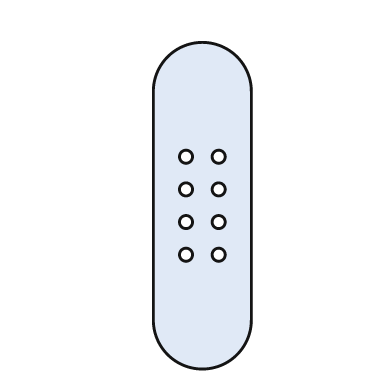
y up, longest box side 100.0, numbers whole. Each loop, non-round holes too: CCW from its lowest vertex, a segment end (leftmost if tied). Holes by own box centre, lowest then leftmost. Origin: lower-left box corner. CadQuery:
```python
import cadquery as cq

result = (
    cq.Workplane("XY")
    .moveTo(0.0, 15.0)
    .threePointArc((15.0, 0.0), (30.0, 15.0))
    .lineTo(30.0, 85.0)
    .threePointArc((15.0, 100.0), (0.0, 85.0))
    .close()
    .moveTo(10.0, 35.0)
    .circle(2.0)
    .moveTo(20.0, 35.0)
    .circle(2.0)
    .moveTo(10.0, 45.0)
    .circle(2.0)
    .moveTo(20.0, 45.0)
    .circle(2.0)
    .moveTo(10.0, 55.0)
    .circle(2.0)
    .moveTo(20.0, 55.0)
    .circle(2.0)
    .moveTo(10.0, 65.0)
    .circle(2.0)
    .moveTo(20.0, 65.0)
    .circle(2.0)
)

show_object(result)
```